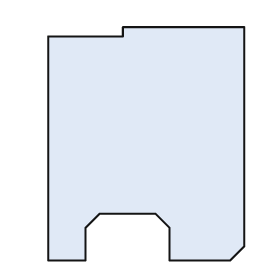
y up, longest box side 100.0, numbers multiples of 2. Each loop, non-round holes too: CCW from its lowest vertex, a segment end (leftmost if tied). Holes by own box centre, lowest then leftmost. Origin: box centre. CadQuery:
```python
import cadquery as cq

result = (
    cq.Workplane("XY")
    .moveTo(-42.0, -50.0)
    .lineTo(-26.0, -50.0)
    .lineTo(-26.0, -36.0)
    .lineTo(-20.0, -30.0)
    .lineTo(4.0, -30.0)
    .lineTo(10.0, -36.0)
    .lineTo(10.0, -50.0)
    .lineTo(36.0, -50.0)
    .lineTo(42.0, -44.0)
    .lineTo(42.0, 50.0)
    .lineTo(-10.0, 50.0)
    .lineTo(-10.0, 46.0)
    .lineTo(-42.0, 46.0)
    .close()
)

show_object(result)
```